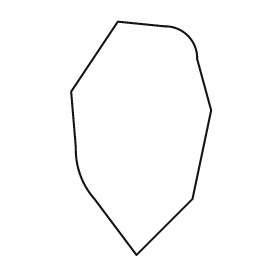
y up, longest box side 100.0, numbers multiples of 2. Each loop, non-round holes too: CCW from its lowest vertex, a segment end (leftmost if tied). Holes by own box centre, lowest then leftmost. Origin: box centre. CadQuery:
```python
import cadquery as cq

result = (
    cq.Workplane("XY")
    .moveTo(-2.0, -50.0)
    .lineTo(22.0, -26.0)
    .lineTo(30.0, 12.0)
    .lineTo(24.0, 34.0)
    .threePointArc((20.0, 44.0), (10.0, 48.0))
    .lineTo(-10.0, 50.0)
    .lineTo(-30.0, 20.0)
    .lineTo(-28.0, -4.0)
    .threePointArc((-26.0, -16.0), (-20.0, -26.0))
    .close()
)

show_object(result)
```